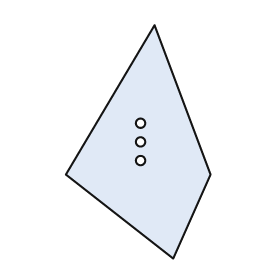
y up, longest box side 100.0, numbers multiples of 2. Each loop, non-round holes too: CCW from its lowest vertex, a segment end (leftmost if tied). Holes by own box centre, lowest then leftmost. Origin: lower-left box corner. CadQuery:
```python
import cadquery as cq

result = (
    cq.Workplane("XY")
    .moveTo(46.0, 0.0)
    .lineTo(62.0, 36.0)
    .lineTo(38.0, 100.0)
    .lineTo(0.0, 36.0)
    .close()
    .moveTo(32.0, 42.0)
    .circle(2.0)
    .moveTo(32.0, 50.0)
    .circle(2.0)
    .moveTo(32.0, 58.0)
    .circle(2.0)
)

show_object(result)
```